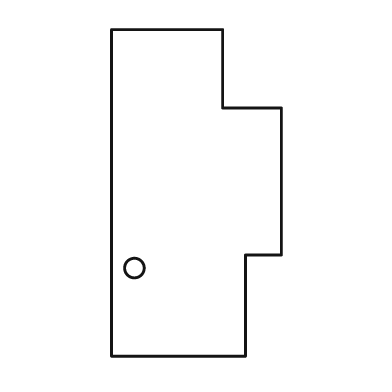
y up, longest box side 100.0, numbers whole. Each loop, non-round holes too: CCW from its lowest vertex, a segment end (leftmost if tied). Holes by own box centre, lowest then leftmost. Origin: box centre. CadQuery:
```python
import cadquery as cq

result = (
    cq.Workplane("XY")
    .moveTo(-26.0, -50.0)
    .lineTo(15.0, -50.0)
    .lineTo(15.0, -19.0)
    .lineTo(26.0, -19.0)
    .lineTo(26.0, 26.0)
    .lineTo(8.0, 26.0)
    .lineTo(8.0, 50.0)
    .lineTo(-26.0, 50.0)
    .close()
    .moveTo(-19.0, -23.0)
    .circle(3.0)
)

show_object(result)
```